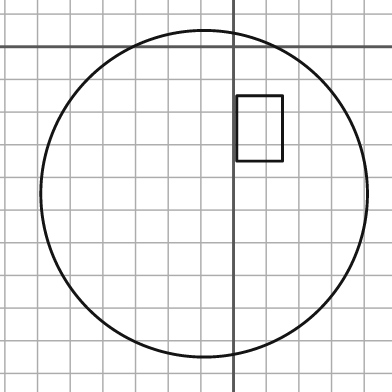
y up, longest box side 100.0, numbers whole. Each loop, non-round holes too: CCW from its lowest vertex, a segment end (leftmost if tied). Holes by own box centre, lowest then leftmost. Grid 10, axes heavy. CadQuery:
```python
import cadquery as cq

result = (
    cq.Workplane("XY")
    .moveTo(-9.0, -45.0)
    .circle(50.0)
    .moveTo(1.0, -35.0)
    .lineTo(15.0, -35.0)
    .lineTo(15.0, -15.0)
    .lineTo(1.0, -15.0)
    .close()
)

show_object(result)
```